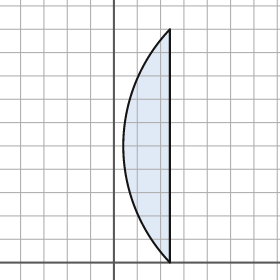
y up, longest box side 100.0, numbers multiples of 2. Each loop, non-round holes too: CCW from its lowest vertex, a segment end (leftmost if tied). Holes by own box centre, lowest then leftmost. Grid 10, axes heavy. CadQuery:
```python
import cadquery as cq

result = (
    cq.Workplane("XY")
    .moveTo(24.0, 0.0)
    .lineTo(24.0, 100.0)
    .threePointArc((4.0, 50.0), (24.0, 0.0))
    .close()
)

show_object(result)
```